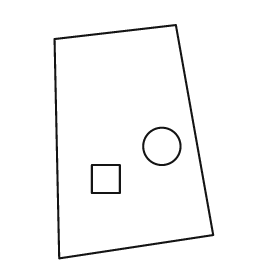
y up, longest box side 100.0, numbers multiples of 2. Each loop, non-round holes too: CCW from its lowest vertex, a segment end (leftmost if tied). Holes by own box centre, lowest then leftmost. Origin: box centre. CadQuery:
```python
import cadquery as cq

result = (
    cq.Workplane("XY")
    .moveTo(-32.0, -50.0)
    .lineTo(34.0, -40.0)
    .lineTo(18.0, 50.0)
    .lineTo(-34.0, 44.0)
    .close()
    .moveTo(-18.0, -22.0)
    .lineTo(-6.0, -22.0)
    .lineTo(-6.0, -10.0)
    .lineTo(-18.0, -10.0)
    .close()
    .moveTo(12.0, -2.0)
    .circle(8.0)
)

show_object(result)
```